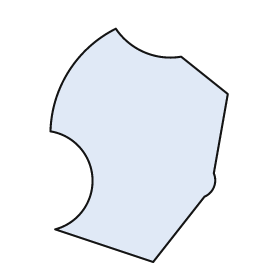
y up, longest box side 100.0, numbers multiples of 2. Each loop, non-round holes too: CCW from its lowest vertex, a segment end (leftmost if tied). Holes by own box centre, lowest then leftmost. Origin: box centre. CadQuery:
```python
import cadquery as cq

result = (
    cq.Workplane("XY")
    .moveTo(6.0, -50.0)
    .lineTo(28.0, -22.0)
    .threePointArc((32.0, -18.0), (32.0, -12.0))
    .lineTo(38.0, 22.0)
    .lineTo(18.0, 38.0)
    .threePointArc((2.0, 40.0), (-10.0, 50.0))
    .threePointArc((-30.0, 32.0), (-38.0, 6.0))
    .threePointArc((-20.0, -14.0), (-36.0, -36.0))
    .close()
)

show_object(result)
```